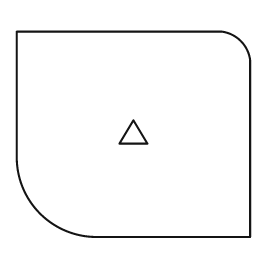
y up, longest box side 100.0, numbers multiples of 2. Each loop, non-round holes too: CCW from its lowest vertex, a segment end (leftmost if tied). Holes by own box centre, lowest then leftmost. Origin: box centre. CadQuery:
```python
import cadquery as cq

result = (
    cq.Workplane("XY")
    .moveTo(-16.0, -44.0)
    .lineTo(50.0, -44.0)
    .lineTo(50.0, 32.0)
    .threePointArc((46.0, 40.0), (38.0, 44.0))
    .lineTo(-50.0, 44.0)
    .lineTo(-50.0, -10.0)
    .threePointArc((-40.0, -34.0), (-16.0, -44.0))
    .close()
    .moveTo(-6.0, -4.0)
    .lineTo(6.0, -4.0)
    .lineTo(0.0, 6.0)
    .close()
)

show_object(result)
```